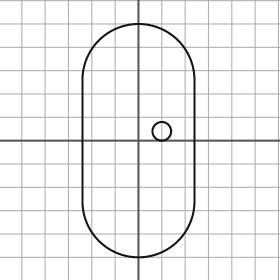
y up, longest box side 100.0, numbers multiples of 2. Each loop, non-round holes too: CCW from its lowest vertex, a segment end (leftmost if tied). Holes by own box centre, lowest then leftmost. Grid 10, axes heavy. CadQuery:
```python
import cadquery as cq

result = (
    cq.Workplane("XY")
    .moveTo(-24.0, -26.0)
    .threePointArc((0.0, -50.0), (24.0, -26.0))
    .lineTo(24.0, 26.0)
    .threePointArc((0.0, 50.0), (-24.0, 26.0))
    .close()
    .moveTo(10.0, 4.0)
    .circle(4.0)
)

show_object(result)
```